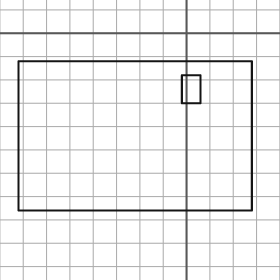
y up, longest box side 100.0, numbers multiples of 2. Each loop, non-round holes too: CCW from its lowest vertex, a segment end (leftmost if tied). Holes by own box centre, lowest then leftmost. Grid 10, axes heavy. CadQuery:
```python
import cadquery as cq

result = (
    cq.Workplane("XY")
    .moveTo(-72.0, -76.0)
    .lineTo(28.0, -76.0)
    .lineTo(28.0, -12.0)
    .lineTo(-72.0, -12.0)
    .close()
    .moveTo(-2.0, -30.0)
    .lineTo(6.0, -30.0)
    .lineTo(6.0, -18.0)
    .lineTo(-2.0, -18.0)
    .close()
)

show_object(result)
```